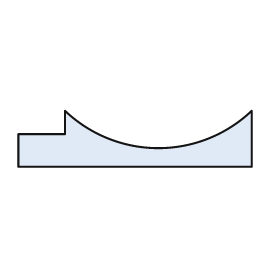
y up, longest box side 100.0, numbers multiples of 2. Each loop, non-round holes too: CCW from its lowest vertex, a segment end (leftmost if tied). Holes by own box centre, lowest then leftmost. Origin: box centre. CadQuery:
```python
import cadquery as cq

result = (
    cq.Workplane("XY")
    .moveTo(-50.0, -12.0)
    .lineTo(50.0, -12.0)
    .lineTo(50.0, 12.0)
    .threePointArc((10.0, -4.0), (-30.0, 12.0))
    .lineTo(-30.0, 2.0)
    .lineTo(-50.0, 2.0)
    .close()
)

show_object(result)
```